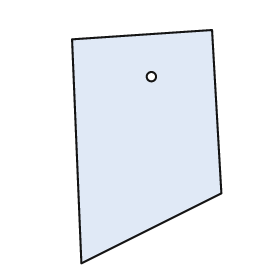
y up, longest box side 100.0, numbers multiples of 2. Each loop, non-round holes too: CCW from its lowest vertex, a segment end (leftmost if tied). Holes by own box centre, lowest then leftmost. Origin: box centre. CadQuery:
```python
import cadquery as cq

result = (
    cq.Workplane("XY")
    .moveTo(-28.0, -50.0)
    .lineTo(32.0, -20.0)
    .lineTo(28.0, 50.0)
    .lineTo(-32.0, 46.0)
    .close()
    .moveTo(2.0, 30.0)
    .circle(2.0)
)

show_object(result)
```